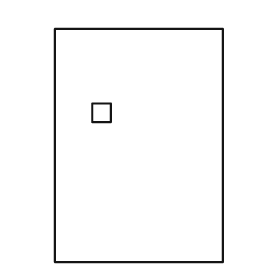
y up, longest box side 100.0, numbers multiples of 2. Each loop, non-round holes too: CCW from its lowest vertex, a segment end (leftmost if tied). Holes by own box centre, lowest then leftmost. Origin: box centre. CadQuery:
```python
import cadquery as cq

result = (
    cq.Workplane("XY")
    .moveTo(-36.0, -50.0)
    .lineTo(36.0, -50.0)
    .lineTo(36.0, 50.0)
    .lineTo(-36.0, 50.0)
    .close()
    .moveTo(-20.0, 10.0)
    .lineTo(-12.0, 10.0)
    .lineTo(-12.0, 18.0)
    .lineTo(-20.0, 18.0)
    .close()
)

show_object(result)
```